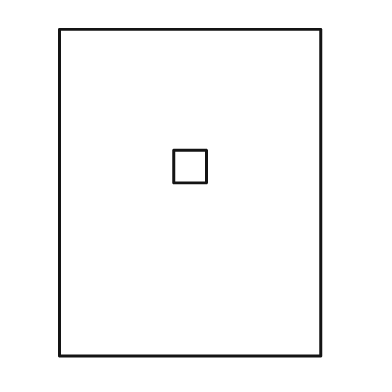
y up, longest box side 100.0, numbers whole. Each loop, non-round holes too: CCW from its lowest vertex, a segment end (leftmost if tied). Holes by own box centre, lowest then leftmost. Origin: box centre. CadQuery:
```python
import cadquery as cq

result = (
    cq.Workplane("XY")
    .moveTo(-40.0, -50.0)
    .lineTo(40.0, -50.0)
    .lineTo(40.0, 50.0)
    .lineTo(-40.0, 50.0)
    .close()
    .moveTo(-5.0, 3.0)
    .lineTo(5.0, 3.0)
    .lineTo(5.0, 13.0)
    .lineTo(-5.0, 13.0)
    .close()
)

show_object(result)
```